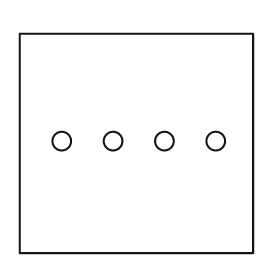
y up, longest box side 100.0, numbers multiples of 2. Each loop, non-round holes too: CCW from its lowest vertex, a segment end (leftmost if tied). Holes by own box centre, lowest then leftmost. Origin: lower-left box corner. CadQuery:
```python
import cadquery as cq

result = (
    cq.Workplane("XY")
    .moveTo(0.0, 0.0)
    .lineTo(100.0, 0.0)
    .lineTo(100.0, 94.0)
    .lineTo(0.0, 94.0)
    .close()
    .moveTo(18.0, 48.0)
    .circle(4.0)
    .moveTo(40.0, 48.0)
    .circle(4.0)
    .moveTo(62.0, 48.0)
    .circle(4.0)
    .moveTo(84.0, 48.0)
    .circle(4.0)
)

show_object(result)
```